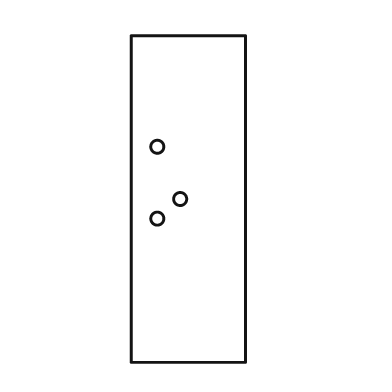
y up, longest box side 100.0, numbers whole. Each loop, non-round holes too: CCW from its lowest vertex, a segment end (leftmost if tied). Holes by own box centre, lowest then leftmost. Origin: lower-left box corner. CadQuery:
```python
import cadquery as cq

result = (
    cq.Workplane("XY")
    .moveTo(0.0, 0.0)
    .lineTo(35.0, 0.0)
    .lineTo(35.0, 100.0)
    .lineTo(0.0, 100.0)
    .close()
    .moveTo(8.0, 44.0)
    .circle(2.0)
    .moveTo(15.0, 50.0)
    .circle(2.0)
    .moveTo(8.0, 66.0)
    .circle(2.0)
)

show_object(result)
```